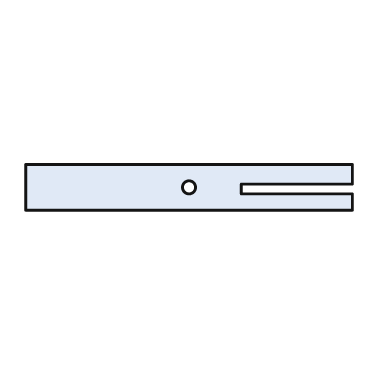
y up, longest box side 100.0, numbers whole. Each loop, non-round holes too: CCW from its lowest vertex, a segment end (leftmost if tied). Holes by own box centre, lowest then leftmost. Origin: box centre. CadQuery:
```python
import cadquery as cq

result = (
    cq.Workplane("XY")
    .moveTo(-50.0, -7.0)
    .lineTo(50.0, -7.0)
    .lineTo(50.0, -2.0)
    .lineTo(16.0, -2.0)
    .lineTo(16.0, 1.0)
    .lineTo(50.0, 1.0)
    .lineTo(50.0, 7.0)
    .lineTo(-50.0, 7.0)
    .close()
    .moveTo(0.0, 0.0)
    .circle(2.0)
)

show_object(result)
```